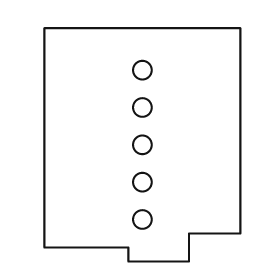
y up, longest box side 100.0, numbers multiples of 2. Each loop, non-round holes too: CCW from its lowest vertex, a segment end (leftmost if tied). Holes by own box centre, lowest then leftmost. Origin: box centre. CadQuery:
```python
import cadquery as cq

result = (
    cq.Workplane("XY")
    .moveTo(-6.0, -50.0)
    .lineTo(20.0, -50.0)
    .lineTo(20.0, -38.0)
    .lineTo(42.0, -38.0)
    .lineTo(42.0, 50.0)
    .lineTo(-42.0, 50.0)
    .lineTo(-42.0, -44.0)
    .lineTo(-6.0, -44.0)
    .close()
    .moveTo(0.0, -32.0)
    .circle(4.0)
    .moveTo(0.0, -16.0)
    .circle(4.0)
    .moveTo(0.0, 0.0)
    .circle(4.0)
    .moveTo(0.0, 16.0)
    .circle(4.0)
    .moveTo(0.0, 32.0)
    .circle(4.0)
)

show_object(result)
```